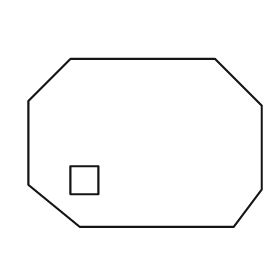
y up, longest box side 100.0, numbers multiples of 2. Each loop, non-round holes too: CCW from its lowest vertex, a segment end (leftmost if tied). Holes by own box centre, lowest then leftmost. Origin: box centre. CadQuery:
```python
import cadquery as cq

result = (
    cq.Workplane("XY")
    .moveTo(-28.0, -36.0)
    .lineTo(38.0, -36.0)
    .lineTo(50.0, -20.0)
    .lineTo(50.0, 16.0)
    .lineTo(30.0, 36.0)
    .lineTo(-32.0, 36.0)
    .lineTo(-50.0, 18.0)
    .lineTo(-50.0, -18.0)
    .close()
    .moveTo(-32.0, -22.0)
    .lineTo(-20.0, -22.0)
    .lineTo(-20.0, -10.0)
    .lineTo(-32.0, -10.0)
    .close()
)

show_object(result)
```